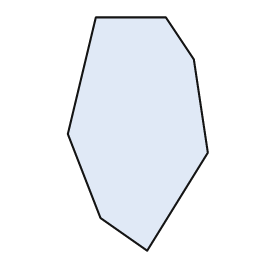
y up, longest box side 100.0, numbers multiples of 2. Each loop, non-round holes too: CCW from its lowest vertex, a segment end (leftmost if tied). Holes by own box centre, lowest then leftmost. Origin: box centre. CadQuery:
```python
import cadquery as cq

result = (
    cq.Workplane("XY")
    .moveTo(4.0, -50.0)
    .lineTo(30.0, -8.0)
    .lineTo(24.0, 32.0)
    .lineTo(12.0, 50.0)
    .lineTo(-18.0, 50.0)
    .lineTo(-30.0, 0.0)
    .lineTo(-16.0, -36.0)
    .close()
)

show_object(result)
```